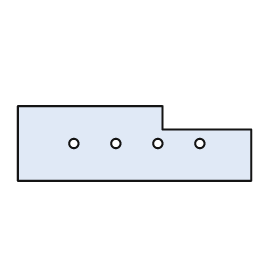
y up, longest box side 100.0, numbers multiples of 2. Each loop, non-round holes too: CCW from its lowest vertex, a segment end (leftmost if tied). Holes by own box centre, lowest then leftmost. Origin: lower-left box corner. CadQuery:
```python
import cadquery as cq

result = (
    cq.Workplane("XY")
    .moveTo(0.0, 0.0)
    .lineTo(100.0, 0.0)
    .lineTo(100.0, 22.0)
    .lineTo(62.0, 22.0)
    .lineTo(62.0, 32.0)
    .lineTo(0.0, 32.0)
    .close()
    .moveTo(24.0, 16.0)
    .circle(2.0)
    .moveTo(42.0, 16.0)
    .circle(2.0)
    .moveTo(60.0, 16.0)
    .circle(2.0)
    .moveTo(78.0, 16.0)
    .circle(2.0)
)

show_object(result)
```